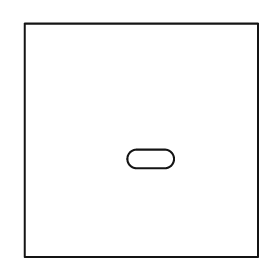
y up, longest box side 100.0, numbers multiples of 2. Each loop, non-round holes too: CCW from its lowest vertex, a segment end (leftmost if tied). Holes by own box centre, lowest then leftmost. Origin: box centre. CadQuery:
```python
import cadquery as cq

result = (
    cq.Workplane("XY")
    .moveTo(-50.0, -50.0)
    .lineTo(50.0, -50.0)
    .lineTo(50.0, 50.0)
    .lineTo(-50.0, 50.0)
    .close()
    .moveTo(-2.0, -12.0)
    .lineTo(10.0, -12.0)
    .threePointArc((14.0, -8.0), (10.0, -4.0))
    .lineTo(-2.0, -4.0)
    .threePointArc((-6.0, -8.0), (-2.0, -12.0))
    .close()
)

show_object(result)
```